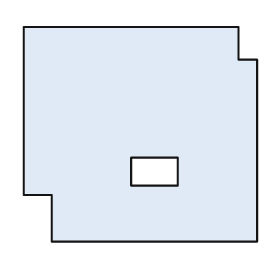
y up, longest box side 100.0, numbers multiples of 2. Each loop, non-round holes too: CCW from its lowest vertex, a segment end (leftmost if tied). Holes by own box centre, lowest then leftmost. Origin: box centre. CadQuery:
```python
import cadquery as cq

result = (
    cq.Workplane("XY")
    .moveTo(-38.0, -46.0)
    .lineTo(50.0, -46.0)
    .lineTo(50.0, 32.0)
    .lineTo(42.0, 32.0)
    .lineTo(42.0, 46.0)
    .lineTo(-50.0, 46.0)
    .lineTo(-50.0, -26.0)
    .lineTo(-38.0, -26.0)
    .close()
    .moveTo(-4.0, -22.0)
    .lineTo(16.0, -22.0)
    .lineTo(16.0, -10.0)
    .lineTo(-4.0, -10.0)
    .close()
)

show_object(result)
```